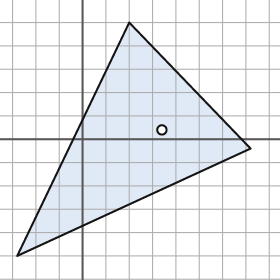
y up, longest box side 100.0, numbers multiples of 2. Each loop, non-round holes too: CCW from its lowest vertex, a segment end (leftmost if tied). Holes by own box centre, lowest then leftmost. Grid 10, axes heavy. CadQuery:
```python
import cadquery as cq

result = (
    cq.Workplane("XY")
    .moveTo(-28.0, -50.0)
    .lineTo(72.0, -4.0)
    .lineTo(20.0, 50.0)
    .close()
    .moveTo(34.0, 4.0)
    .circle(2.0)
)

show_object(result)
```